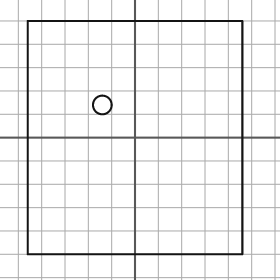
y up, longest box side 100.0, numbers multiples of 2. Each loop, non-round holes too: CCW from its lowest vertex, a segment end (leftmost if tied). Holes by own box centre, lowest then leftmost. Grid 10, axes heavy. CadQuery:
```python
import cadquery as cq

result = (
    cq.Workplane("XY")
    .moveTo(-46.0, -50.0)
    .lineTo(46.0, -50.0)
    .lineTo(46.0, 50.0)
    .lineTo(-46.0, 50.0)
    .close()
    .moveTo(-14.0, 14.0)
    .circle(4.0)
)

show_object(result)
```